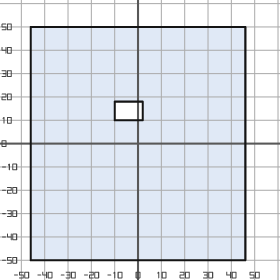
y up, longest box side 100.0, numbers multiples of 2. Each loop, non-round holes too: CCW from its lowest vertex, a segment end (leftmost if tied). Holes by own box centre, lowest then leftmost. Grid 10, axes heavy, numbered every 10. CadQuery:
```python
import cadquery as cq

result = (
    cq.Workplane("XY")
    .moveTo(-46.0, -50.0)
    .lineTo(46.0, -50.0)
    .lineTo(46.0, 50.0)
    .lineTo(-46.0, 50.0)
    .close()
    .moveTo(-10.0, 10.0)
    .lineTo(2.0, 10.0)
    .lineTo(2.0, 18.0)
    .lineTo(-10.0, 18.0)
    .close()
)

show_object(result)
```